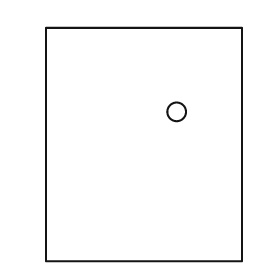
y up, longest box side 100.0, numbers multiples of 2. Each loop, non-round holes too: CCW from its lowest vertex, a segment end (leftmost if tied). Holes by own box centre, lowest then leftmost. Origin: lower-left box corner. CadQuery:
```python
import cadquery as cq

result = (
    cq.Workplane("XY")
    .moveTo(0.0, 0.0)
    .lineTo(84.0, 0.0)
    .lineTo(84.0, 100.0)
    .lineTo(0.0, 100.0)
    .close()
    .moveTo(56.0, 64.0)
    .circle(4.0)
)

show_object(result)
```